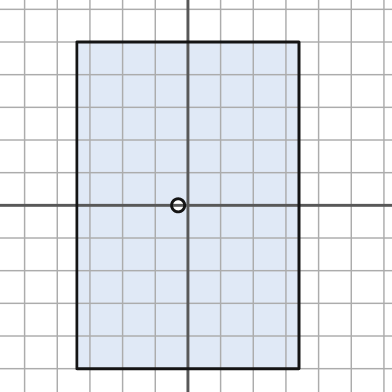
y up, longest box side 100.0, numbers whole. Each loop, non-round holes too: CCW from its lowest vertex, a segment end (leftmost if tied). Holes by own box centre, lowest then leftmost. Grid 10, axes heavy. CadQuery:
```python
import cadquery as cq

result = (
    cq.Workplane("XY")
    .moveTo(-34.0, -50.0)
    .lineTo(34.0, -50.0)
    .lineTo(34.0, 50.0)
    .lineTo(-34.0, 50.0)
    .close()
    .moveTo(-3.0, 0.0)
    .circle(2.0)
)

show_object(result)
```